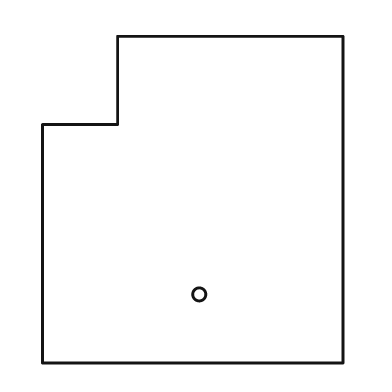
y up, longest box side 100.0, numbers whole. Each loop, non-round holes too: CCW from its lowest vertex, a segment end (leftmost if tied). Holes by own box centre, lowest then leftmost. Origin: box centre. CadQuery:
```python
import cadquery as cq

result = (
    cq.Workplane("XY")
    .moveTo(-46.0, -50.0)
    .lineTo(46.0, -50.0)
    .lineTo(46.0, 50.0)
    .lineTo(-23.0, 50.0)
    .lineTo(-23.0, 23.0)
    .lineTo(-46.0, 23.0)
    .close()
    .moveTo(2.0, -29.0)
    .circle(2.0)
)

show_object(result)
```